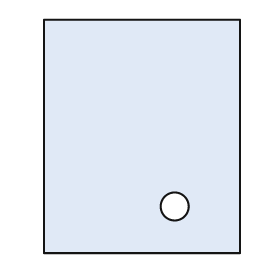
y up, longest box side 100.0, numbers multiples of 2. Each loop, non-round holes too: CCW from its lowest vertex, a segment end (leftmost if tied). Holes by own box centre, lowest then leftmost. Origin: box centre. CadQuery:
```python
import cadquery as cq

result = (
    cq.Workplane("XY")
    .moveTo(-42.0, -50.0)
    .lineTo(42.0, -50.0)
    .lineTo(42.0, 50.0)
    .lineTo(-42.0, 50.0)
    .close()
    .moveTo(14.0, -30.0)
    .circle(6.0)
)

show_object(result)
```